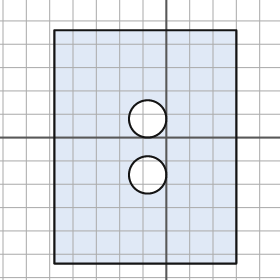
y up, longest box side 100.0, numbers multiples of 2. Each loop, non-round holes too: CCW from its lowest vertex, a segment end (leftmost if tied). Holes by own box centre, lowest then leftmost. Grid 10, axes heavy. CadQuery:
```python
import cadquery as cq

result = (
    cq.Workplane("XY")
    .moveTo(-48.0, -54.0)
    .lineTo(30.0, -54.0)
    .lineTo(30.0, 46.0)
    .lineTo(-48.0, 46.0)
    .close()
    .moveTo(-8.0, -16.0)
    .circle(8.0)
    .moveTo(-8.0, 8.0)
    .circle(8.0)
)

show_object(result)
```